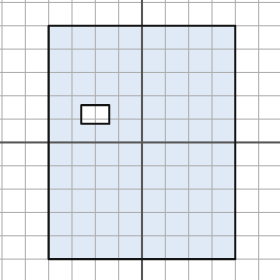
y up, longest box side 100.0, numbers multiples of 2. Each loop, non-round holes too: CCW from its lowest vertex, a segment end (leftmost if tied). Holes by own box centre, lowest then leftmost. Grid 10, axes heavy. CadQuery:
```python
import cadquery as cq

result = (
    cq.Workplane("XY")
    .moveTo(-40.0, -50.0)
    .lineTo(40.0, -50.0)
    .lineTo(40.0, 50.0)
    .lineTo(-40.0, 50.0)
    .close()
    .moveTo(-26.0, 8.0)
    .lineTo(-14.0, 8.0)
    .lineTo(-14.0, 16.0)
    .lineTo(-26.0, 16.0)
    .close()
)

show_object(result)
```